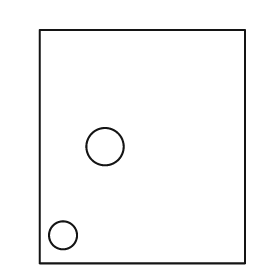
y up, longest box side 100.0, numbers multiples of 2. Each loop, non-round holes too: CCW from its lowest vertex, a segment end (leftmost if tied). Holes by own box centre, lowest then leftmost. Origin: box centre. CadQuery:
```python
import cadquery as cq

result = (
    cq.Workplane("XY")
    .moveTo(-44.0, -50.0)
    .lineTo(44.0, -50.0)
    .lineTo(44.0, 50.0)
    .lineTo(-44.0, 50.0)
    .close()
    .moveTo(-34.0, -38.0)
    .circle(6.0)
    .moveTo(-16.0, 0.0)
    .circle(8.0)
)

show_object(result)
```